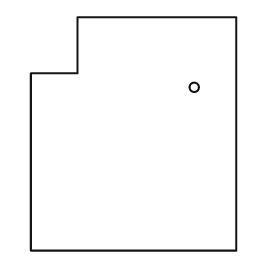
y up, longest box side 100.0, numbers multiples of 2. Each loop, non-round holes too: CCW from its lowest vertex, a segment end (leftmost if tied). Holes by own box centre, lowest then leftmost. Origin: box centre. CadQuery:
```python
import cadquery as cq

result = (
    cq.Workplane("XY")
    .moveTo(-44.0, -50.0)
    .lineTo(44.0, -50.0)
    .lineTo(44.0, 50.0)
    .lineTo(-24.0, 50.0)
    .lineTo(-24.0, 26.0)
    .lineTo(-44.0, 26.0)
    .close()
    .moveTo(26.0, 20.0)
    .circle(2.0)
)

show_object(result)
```